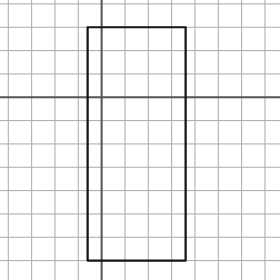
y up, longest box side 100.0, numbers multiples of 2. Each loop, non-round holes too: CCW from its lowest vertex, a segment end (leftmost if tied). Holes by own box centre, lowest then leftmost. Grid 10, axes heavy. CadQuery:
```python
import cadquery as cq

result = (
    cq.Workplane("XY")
    .moveTo(-6.0, -70.0)
    .lineTo(36.0, -70.0)
    .lineTo(36.0, 30.0)
    .lineTo(-6.0, 30.0)
    .close()
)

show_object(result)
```